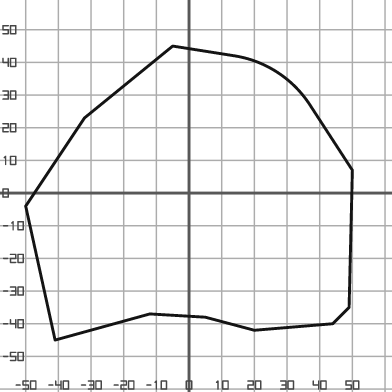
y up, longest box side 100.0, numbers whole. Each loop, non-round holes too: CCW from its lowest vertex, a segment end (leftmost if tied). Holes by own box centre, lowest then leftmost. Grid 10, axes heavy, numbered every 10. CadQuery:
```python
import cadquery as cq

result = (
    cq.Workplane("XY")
    .moveTo(-41.0, -45.0)
    .lineTo(-12.0, -37.0)
    .lineTo(5.0, -38.0)
    .lineTo(20.0, -42.0)
    .lineTo(44.0, -40.0)
    .lineTo(49.0, -35.0)
    .lineTo(50.0, 7.0)
    .lineTo(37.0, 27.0)
    .threePointArc((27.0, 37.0), (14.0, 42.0))
    .lineTo(-5.0, 45.0)
    .lineTo(-32.0, 23.0)
    .lineTo(-50.0, -4.0)
    .close()
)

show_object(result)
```